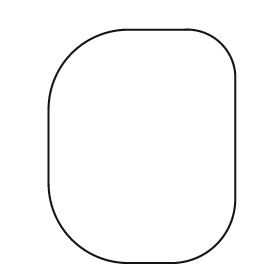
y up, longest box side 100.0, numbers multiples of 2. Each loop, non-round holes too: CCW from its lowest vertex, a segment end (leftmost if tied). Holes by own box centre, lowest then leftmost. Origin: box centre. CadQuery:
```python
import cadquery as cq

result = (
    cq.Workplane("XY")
    .moveTo(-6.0, -50.0)
    .lineTo(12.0, -50.0)
    .threePointArc((32.0, -42.0), (40.0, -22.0))
    .lineTo(40.0, 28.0)
    .threePointArc((34.0, 44.0), (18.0, 50.0))
    .lineTo(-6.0, 50.0)
    .threePointArc((-30.0, 40.0), (-40.0, 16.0))
    .lineTo(-40.0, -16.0)
    .threePointArc((-30.0, -40.0), (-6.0, -50.0))
    .close()
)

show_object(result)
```